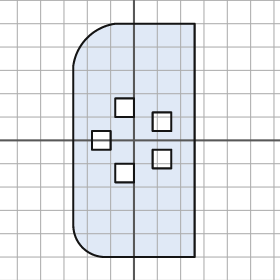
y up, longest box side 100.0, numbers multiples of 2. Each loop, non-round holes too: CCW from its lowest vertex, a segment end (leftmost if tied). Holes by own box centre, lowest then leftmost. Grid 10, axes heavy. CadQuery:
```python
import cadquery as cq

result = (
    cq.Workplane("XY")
    .moveTo(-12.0, -50.0)
    .lineTo(26.0, -50.0)
    .lineTo(26.0, 50.0)
    .lineTo(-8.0, 50.0)
    .threePointArc((-20.0, 44.0), (-26.0, 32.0))
    .lineTo(-26.0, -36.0)
    .threePointArc((-22.0, -46.0), (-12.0, -50.0))
    .close()
    .moveTo(-8.0, -18.0)
    .lineTo(0.0, -18.0)
    .lineTo(0.0, -10.0)
    .lineTo(-8.0, -10.0)
    .close()
    .moveTo(8.0, -12.0)
    .lineTo(16.0, -12.0)
    .lineTo(16.0, -4.0)
    .lineTo(8.0, -4.0)
    .close()
    .moveTo(-18.0, -4.0)
    .lineTo(-10.0, -4.0)
    .lineTo(-10.0, 4.0)
    .lineTo(-18.0, 4.0)
    .close()
    .moveTo(8.0, 4.0)
    .lineTo(16.0, 4.0)
    .lineTo(16.0, 12.0)
    .lineTo(8.0, 12.0)
    .close()
    .moveTo(-8.0, 10.0)
    .lineTo(0.0, 10.0)
    .lineTo(0.0, 18.0)
    .lineTo(-8.0, 18.0)
    .close()
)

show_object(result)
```